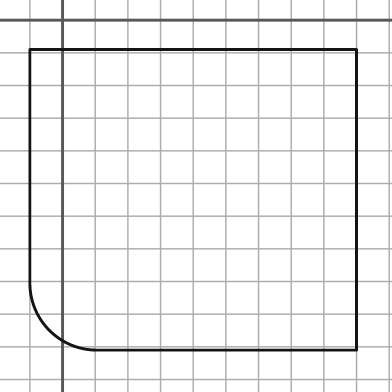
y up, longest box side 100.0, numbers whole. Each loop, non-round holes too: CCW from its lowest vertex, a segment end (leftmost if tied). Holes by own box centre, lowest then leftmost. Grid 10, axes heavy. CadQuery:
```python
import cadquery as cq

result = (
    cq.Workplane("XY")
    .moveTo(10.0, -101.0)
    .lineTo(90.0, -101.0)
    .lineTo(90.0, -9.0)
    .lineTo(-10.0, -9.0)
    .lineTo(-10.0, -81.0)
    .threePointArc((-4.0, -95.0), (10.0, -101.0))
    .close()
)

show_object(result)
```